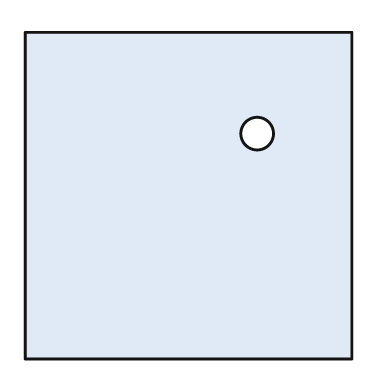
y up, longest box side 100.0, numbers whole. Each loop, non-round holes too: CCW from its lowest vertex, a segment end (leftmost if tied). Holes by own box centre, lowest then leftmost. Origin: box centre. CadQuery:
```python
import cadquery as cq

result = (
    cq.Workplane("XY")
    .moveTo(-50.0, -50.0)
    .lineTo(50.0, -50.0)
    .lineTo(50.0, 50.0)
    .lineTo(-50.0, 50.0)
    .close()
    .moveTo(21.0, 19.0)
    .circle(5.0)
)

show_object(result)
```